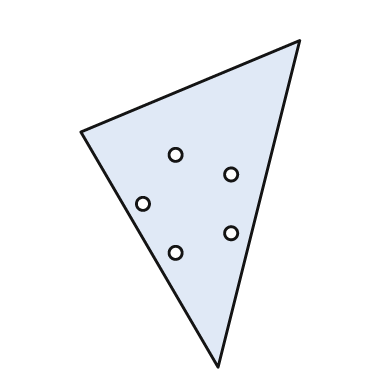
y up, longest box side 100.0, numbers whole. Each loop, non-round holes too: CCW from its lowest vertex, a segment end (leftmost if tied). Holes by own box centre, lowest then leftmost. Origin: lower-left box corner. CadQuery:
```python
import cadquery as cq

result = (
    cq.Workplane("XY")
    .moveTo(42.0, 0.0)
    .lineTo(67.0, 100.0)
    .lineTo(0.0, 72.0)
    .close()
    .moveTo(29.0, 35.0)
    .circle(2.0)
    .moveTo(46.0, 41.0)
    .circle(2.0)
    .moveTo(19.0, 50.0)
    .circle(2.0)
    .moveTo(46.0, 59.0)
    .circle(2.0)
    .moveTo(29.0, 65.0)
    .circle(2.0)
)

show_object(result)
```